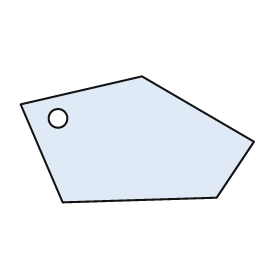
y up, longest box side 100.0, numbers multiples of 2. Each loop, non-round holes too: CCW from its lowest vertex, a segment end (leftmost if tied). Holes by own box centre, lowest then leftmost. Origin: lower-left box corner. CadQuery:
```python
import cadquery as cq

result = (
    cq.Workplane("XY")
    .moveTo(18.0, 0.0)
    .lineTo(84.0, 2.0)
    .lineTo(100.0, 26.0)
    .lineTo(52.0, 54.0)
    .lineTo(0.0, 42.0)
    .close()
    .moveTo(16.0, 36.0)
    .circle(4.0)
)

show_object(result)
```